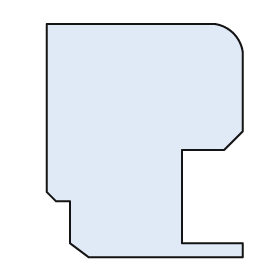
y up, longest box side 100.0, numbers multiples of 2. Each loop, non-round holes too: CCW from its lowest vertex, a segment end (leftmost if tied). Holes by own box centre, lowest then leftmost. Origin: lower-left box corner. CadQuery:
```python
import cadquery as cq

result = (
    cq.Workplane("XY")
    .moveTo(18.0, 0.0)
    .lineTo(84.0, 0.0)
    .lineTo(84.0, 6.0)
    .lineTo(58.0, 6.0)
    .lineTo(58.0, 46.0)
    .lineTo(76.0, 46.0)
    .lineTo(84.0, 54.0)
    .lineTo(84.0, 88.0)
    .threePointArc((80.0, 96.0), (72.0, 100.0))
    .lineTo(0.0, 100.0)
    .lineTo(0.0, 28.0)
    .lineTo(4.0, 24.0)
    .lineTo(10.0, 24.0)
    .lineTo(10.0, 6.0)
    .close()
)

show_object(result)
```